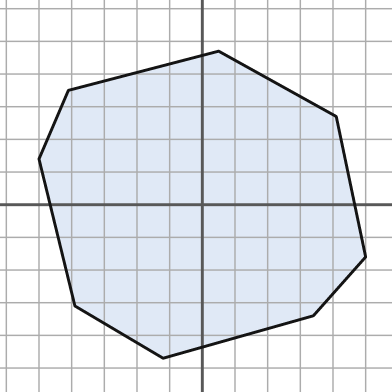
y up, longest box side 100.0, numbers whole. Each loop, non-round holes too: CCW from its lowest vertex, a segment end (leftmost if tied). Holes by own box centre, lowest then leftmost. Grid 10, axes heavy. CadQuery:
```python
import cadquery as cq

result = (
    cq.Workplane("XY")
    .moveTo(-12.0, -47.0)
    .lineTo(34.0, -34.0)
    .lineTo(50.0, -16.0)
    .lineTo(41.0, 27.0)
    .lineTo(5.0, 47.0)
    .lineTo(-41.0, 35.0)
    .lineTo(-50.0, 14.0)
    .lineTo(-39.0, -31.0)
    .close()
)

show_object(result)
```